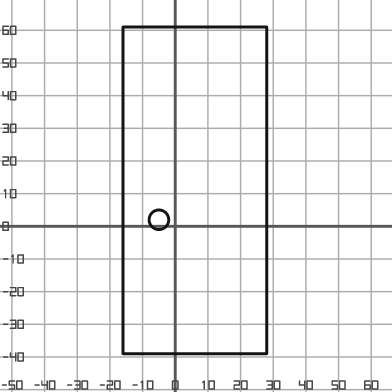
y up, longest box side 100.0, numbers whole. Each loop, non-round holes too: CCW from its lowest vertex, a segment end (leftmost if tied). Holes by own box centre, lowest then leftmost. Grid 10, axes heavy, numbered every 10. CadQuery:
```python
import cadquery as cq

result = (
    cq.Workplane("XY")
    .moveTo(-16.0, -39.0)
    .lineTo(28.0, -39.0)
    .lineTo(28.0, 61.0)
    .lineTo(-16.0, 61.0)
    .close()
    .moveTo(-5.0, 2.0)
    .circle(3.0)
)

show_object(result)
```